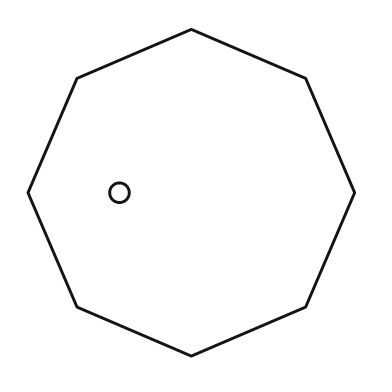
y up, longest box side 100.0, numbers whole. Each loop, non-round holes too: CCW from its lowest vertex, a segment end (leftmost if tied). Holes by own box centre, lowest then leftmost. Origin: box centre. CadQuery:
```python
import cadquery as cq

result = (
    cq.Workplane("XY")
    .moveTo(0.0, -50.0)
    .lineTo(35.0, -35.0)
    .lineTo(50.0, 0.0)
    .lineTo(35.0, 35.0)
    .lineTo(0.0, 50.0)
    .lineTo(-35.0, 35.0)
    .lineTo(-50.0, 0.0)
    .lineTo(-35.0, -35.0)
    .close()
    .moveTo(-22.0, 0.0)
    .circle(3.0)
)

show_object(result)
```